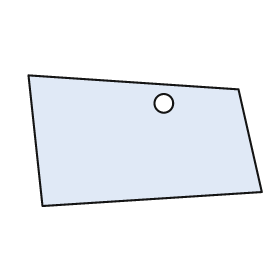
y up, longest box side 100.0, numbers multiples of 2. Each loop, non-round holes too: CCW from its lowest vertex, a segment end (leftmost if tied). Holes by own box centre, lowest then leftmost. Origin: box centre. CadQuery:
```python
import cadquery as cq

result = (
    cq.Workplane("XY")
    .moveTo(-44.0, -28.0)
    .lineTo(50.0, -22.0)
    .lineTo(40.0, 22.0)
    .lineTo(-50.0, 28.0)
    .close()
    .moveTo(8.0, 16.0)
    .circle(4.0)
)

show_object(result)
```